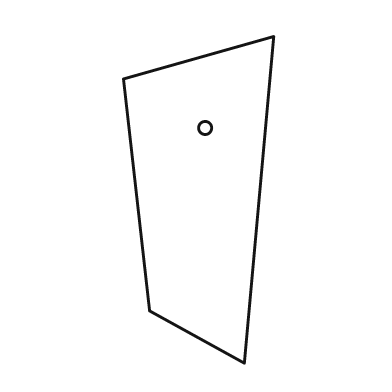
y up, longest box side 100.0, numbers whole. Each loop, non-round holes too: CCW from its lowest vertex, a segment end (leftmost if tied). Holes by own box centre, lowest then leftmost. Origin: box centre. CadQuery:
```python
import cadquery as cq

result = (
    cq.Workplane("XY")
    .moveTo(14.0, -50.0)
    .lineTo(23.0, 50.0)
    .lineTo(-23.0, 37.0)
    .lineTo(-15.0, -34.0)
    .close()
    .moveTo(2.0, 22.0)
    .circle(2.0)
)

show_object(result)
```